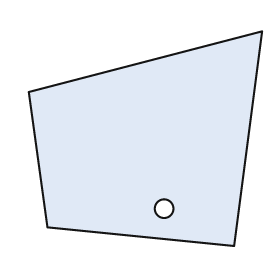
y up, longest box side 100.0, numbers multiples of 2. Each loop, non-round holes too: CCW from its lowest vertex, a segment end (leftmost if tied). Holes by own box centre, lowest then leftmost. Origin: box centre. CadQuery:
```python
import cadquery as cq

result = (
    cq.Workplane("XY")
    .moveTo(38.0, -46.0)
    .lineTo(50.0, 46.0)
    .lineTo(-50.0, 20.0)
    .lineTo(-42.0, -38.0)
    .close()
    .moveTo(8.0, -30.0)
    .circle(4.0)
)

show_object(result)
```